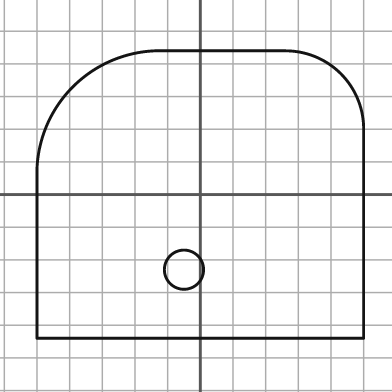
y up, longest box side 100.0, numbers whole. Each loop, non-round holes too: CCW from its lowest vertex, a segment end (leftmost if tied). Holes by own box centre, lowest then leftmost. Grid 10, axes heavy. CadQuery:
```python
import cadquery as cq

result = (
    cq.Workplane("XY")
    .moveTo(-50.0, -44.0)
    .lineTo(50.0, -44.0)
    .lineTo(50.0, 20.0)
    .threePointArc((43.0, 37.0), (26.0, 44.0))
    .lineTo(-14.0, 44.0)
    .threePointArc((-39.0, 33.0), (-50.0, 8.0))
    .close()
    .moveTo(-5.0, -23.0)
    .circle(6.0)
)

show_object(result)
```